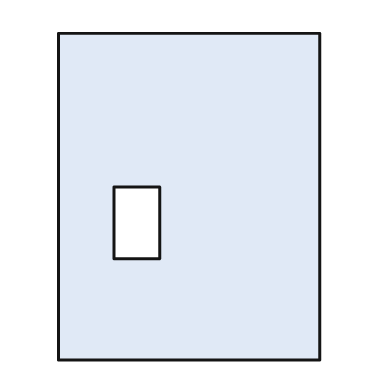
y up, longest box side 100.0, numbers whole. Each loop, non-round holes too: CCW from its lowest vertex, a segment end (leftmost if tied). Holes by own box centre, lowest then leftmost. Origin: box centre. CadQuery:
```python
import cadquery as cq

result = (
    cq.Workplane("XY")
    .moveTo(-40.0, -50.0)
    .lineTo(40.0, -50.0)
    .lineTo(40.0, 50.0)
    .lineTo(-40.0, 50.0)
    .close()
    .moveTo(-23.0, -19.0)
    .lineTo(-9.0, -19.0)
    .lineTo(-9.0, 3.0)
    .lineTo(-23.0, 3.0)
    .close()
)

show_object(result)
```